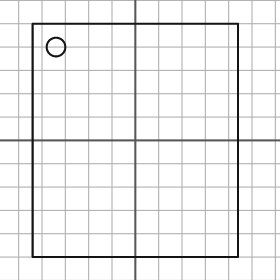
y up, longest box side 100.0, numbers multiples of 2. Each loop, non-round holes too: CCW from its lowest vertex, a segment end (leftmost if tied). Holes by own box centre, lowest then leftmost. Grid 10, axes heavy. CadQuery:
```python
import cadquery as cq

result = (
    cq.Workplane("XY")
    .moveTo(-44.0, -50.0)
    .lineTo(44.0, -50.0)
    .lineTo(44.0, 50.0)
    .lineTo(-44.0, 50.0)
    .close()
    .moveTo(-34.0, 40.0)
    .circle(4.0)
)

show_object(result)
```